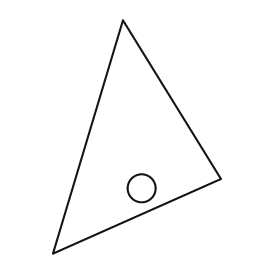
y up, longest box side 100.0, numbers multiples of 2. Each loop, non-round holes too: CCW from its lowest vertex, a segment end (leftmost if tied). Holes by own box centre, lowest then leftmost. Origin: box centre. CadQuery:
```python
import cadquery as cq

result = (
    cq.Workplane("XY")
    .moveTo(-36.0, -50.0)
    .lineTo(36.0, -18.0)
    .lineTo(-6.0, 50.0)
    .close()
    .moveTo(2.0, -22.0)
    .circle(6.0)
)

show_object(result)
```